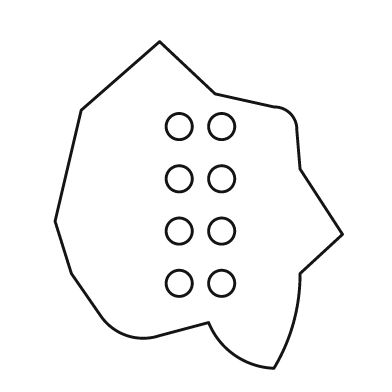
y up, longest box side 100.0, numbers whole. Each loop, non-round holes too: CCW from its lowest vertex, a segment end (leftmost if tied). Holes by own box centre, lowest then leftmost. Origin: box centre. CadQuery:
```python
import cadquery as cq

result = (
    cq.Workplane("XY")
    .moveTo(23.0, -50.0)
    .threePointArc((29.0, -36.0), (31.0, -21.0))
    .lineTo(44.0, -9.0)
    .lineTo(31.0, 11.0)
    .lineTo(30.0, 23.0)
    .threePointArc((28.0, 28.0), (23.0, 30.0))
    .lineTo(5.0, 34.0)
    .lineTo(-12.0, 50.0)
    .lineTo(-36.0, 29.0)
    .lineTo(-44.0, -5.0)
    .lineTo(-39.0, -21.0)
    .lineTo(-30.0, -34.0)
    .threePointArc((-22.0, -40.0), (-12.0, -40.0))
    .lineTo(3.0, -36.0)
    .threePointArc((11.0, -46.0), (23.0, -50.0))
    .close()
    .moveTo(-6.0, -24.0)
    .circle(4.0)
    .moveTo(7.0, -24.0)
    .circle(4.0)
    .moveTo(-6.0, -8.0)
    .circle(4.0)
    .moveTo(7.0, -8.0)
    .circle(4.0)
    .moveTo(-6.0, 8.0)
    .circle(4.0)
    .moveTo(7.0, 8.0)
    .circle(4.0)
    .moveTo(-6.0, 24.0)
    .circle(4.0)
    .moveTo(7.0, 24.0)
    .circle(4.0)
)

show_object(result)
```